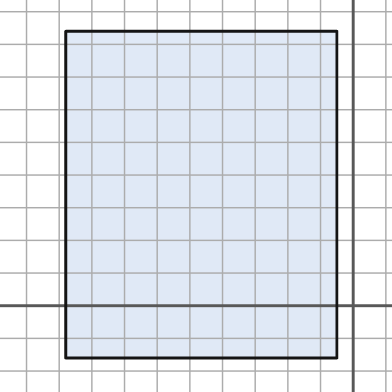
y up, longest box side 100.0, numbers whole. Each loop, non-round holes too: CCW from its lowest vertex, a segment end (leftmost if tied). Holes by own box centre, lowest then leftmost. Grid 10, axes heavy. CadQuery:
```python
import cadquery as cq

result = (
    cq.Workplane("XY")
    .moveTo(-88.0, -16.0)
    .lineTo(-5.0, -16.0)
    .lineTo(-5.0, 84.0)
    .lineTo(-88.0, 84.0)
    .close()
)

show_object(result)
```